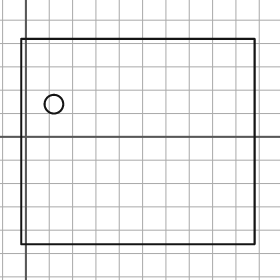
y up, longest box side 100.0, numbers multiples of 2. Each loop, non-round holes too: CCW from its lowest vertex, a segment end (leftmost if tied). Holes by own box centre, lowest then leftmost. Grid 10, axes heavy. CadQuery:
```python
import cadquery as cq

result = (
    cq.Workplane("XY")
    .moveTo(-2.0, -46.0)
    .lineTo(98.0, -46.0)
    .lineTo(98.0, 42.0)
    .lineTo(-2.0, 42.0)
    .close()
    .moveTo(12.0, 14.0)
    .circle(4.0)
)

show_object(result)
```